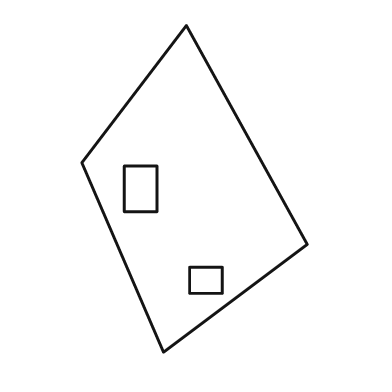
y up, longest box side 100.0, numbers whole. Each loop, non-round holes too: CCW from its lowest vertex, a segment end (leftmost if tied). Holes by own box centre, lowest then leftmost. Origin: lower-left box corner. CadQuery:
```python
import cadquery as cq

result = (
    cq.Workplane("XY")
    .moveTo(25.0, 0.0)
    .lineTo(69.0, 33.0)
    .lineTo(32.0, 100.0)
    .lineTo(0.0, 58.0)
    .close()
    .moveTo(33.0, 18.0)
    .lineTo(43.0, 18.0)
    .lineTo(43.0, 26.0)
    .lineTo(33.0, 26.0)
    .close()
    .moveTo(13.0, 43.0)
    .lineTo(23.0, 43.0)
    .lineTo(23.0, 57.0)
    .lineTo(13.0, 57.0)
    .close()
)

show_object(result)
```